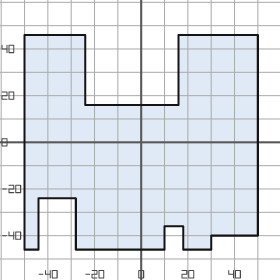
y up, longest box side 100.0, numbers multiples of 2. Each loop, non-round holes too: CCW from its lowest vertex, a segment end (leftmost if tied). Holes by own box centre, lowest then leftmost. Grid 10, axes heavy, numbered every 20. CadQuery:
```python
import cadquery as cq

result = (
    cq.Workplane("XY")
    .moveTo(-50.0, -46.0)
    .lineTo(-44.0, -46.0)
    .lineTo(-44.0, -24.0)
    .lineTo(-28.0, -24.0)
    .lineTo(-28.0, -46.0)
    .lineTo(10.0, -46.0)
    .lineTo(10.0, -36.0)
    .lineTo(18.0, -36.0)
    .lineTo(18.0, -46.0)
    .lineTo(30.0, -46.0)
    .lineTo(30.0, -40.0)
    .lineTo(50.0, -40.0)
    .lineTo(50.0, 46.0)
    .lineTo(16.0, 46.0)
    .lineTo(16.0, 16.0)
    .lineTo(-24.0, 16.0)
    .lineTo(-24.0, 46.0)
    .lineTo(-50.0, 46.0)
    .close()
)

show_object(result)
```